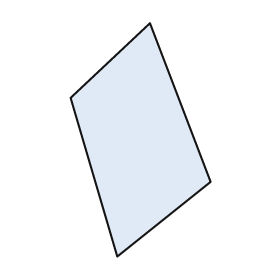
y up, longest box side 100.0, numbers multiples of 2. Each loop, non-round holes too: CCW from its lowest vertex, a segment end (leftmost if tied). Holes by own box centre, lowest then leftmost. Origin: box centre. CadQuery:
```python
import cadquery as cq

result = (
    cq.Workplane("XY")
    .moveTo(-10.0, -50.0)
    .lineTo(30.0, -18.0)
    .lineTo(4.0, 50.0)
    .lineTo(-30.0, 18.0)
    .close()
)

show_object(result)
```